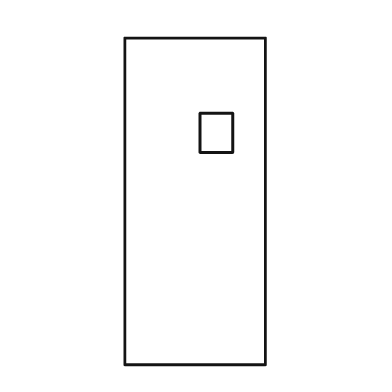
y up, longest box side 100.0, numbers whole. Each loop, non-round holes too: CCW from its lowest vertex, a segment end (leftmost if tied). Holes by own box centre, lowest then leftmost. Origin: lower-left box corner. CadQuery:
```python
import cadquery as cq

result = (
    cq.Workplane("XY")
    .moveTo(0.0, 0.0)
    .lineTo(43.0, 0.0)
    .lineTo(43.0, 100.0)
    .lineTo(0.0, 100.0)
    .close()
    .moveTo(23.0, 65.0)
    .lineTo(33.0, 65.0)
    .lineTo(33.0, 77.0)
    .lineTo(23.0, 77.0)
    .close()
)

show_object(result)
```